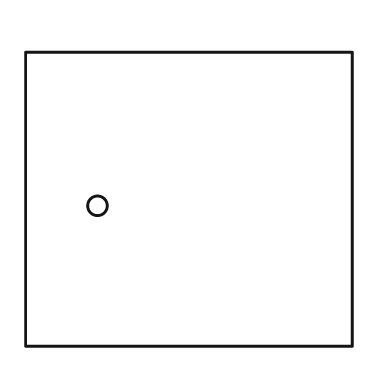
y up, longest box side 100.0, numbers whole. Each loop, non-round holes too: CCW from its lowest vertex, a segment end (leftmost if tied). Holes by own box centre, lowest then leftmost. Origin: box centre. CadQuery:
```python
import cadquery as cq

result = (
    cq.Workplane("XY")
    .moveTo(-50.0, -45.0)
    .lineTo(50.0, -45.0)
    .lineTo(50.0, 45.0)
    .lineTo(-50.0, 45.0)
    .close()
    .moveTo(-28.0, -2.0)
    .circle(3.0)
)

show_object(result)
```